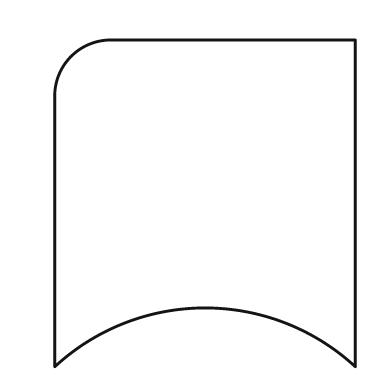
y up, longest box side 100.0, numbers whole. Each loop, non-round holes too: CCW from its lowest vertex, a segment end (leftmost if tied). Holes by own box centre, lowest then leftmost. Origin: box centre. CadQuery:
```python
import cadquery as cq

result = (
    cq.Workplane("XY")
    .moveTo(-46.0, -50.0)
    .threePointArc((0.0, -32.0), (46.0, -50.0))
    .lineTo(46.0, 50.0)
    .lineTo(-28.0, 50.0)
    .threePointArc((-41.0, 45.0), (-46.0, 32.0))
    .close()
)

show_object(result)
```